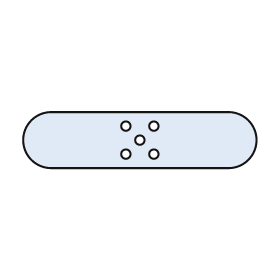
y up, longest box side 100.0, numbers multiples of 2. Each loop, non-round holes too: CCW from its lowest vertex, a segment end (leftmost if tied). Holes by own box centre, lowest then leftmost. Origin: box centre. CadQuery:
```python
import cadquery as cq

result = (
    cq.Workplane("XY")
    .moveTo(-38.0, -12.0)
    .lineTo(38.0, -12.0)
    .threePointArc((50.0, 0.0), (38.0, 12.0))
    .lineTo(-38.0, 12.0)
    .threePointArc((-50.0, 0.0), (-38.0, -12.0))
    .close()
    .moveTo(-6.0, -6.0)
    .circle(2.0)
    .moveTo(6.0, -6.0)
    .circle(2.0)
    .moveTo(0.0, 0.0)
    .circle(2.0)
    .moveTo(-6.0, 6.0)
    .circle(2.0)
    .moveTo(6.0, 6.0)
    .circle(2.0)
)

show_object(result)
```